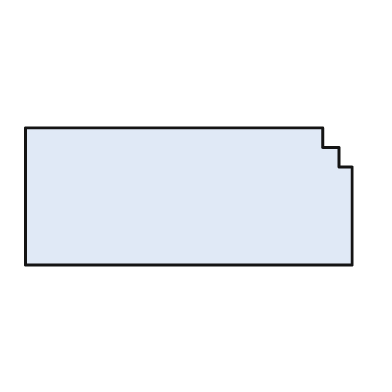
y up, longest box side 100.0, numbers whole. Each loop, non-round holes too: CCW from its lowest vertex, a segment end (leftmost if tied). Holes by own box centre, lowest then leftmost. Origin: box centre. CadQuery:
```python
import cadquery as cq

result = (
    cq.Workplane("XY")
    .moveTo(-50.0, -21.0)
    .lineTo(50.0, -21.0)
    .lineTo(50.0, 9.0)
    .lineTo(46.0, 9.0)
    .lineTo(46.0, 15.0)
    .lineTo(41.0, 15.0)
    .lineTo(41.0, 21.0)
    .lineTo(-50.0, 21.0)
    .close()
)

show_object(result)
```